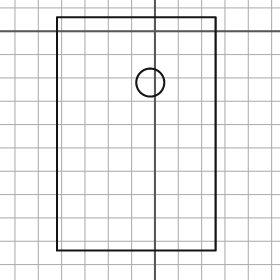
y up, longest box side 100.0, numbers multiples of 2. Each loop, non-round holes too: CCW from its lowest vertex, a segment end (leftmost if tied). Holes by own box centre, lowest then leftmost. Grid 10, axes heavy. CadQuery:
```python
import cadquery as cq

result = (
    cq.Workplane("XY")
    .moveTo(-42.0, -94.0)
    .lineTo(26.0, -94.0)
    .lineTo(26.0, 6.0)
    .lineTo(-42.0, 6.0)
    .close()
    .moveTo(-2.0, -22.0)
    .circle(6.0)
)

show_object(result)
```